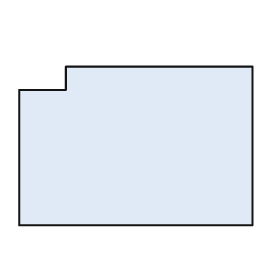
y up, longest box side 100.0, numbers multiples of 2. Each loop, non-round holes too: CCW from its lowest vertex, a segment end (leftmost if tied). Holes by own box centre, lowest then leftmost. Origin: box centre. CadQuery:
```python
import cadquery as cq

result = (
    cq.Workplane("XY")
    .moveTo(-50.0, -34.0)
    .lineTo(50.0, -34.0)
    .lineTo(50.0, 34.0)
    .lineTo(-30.0, 34.0)
    .lineTo(-30.0, 24.0)
    .lineTo(-50.0, 24.0)
    .close()
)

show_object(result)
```